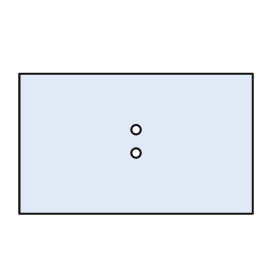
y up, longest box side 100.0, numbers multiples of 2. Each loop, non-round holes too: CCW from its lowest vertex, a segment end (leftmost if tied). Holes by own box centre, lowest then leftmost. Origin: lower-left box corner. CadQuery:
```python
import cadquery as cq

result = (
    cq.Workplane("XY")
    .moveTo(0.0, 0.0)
    .lineTo(100.0, 0.0)
    .lineTo(100.0, 60.0)
    .lineTo(0.0, 60.0)
    .close()
    .moveTo(50.0, 26.0)
    .circle(2.0)
    .moveTo(50.0, 36.0)
    .circle(2.0)
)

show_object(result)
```